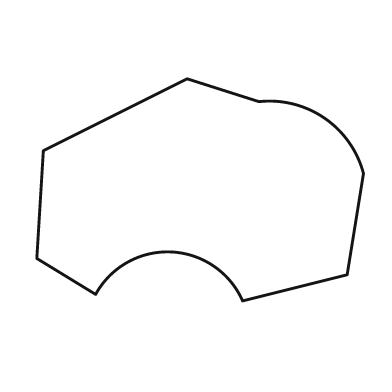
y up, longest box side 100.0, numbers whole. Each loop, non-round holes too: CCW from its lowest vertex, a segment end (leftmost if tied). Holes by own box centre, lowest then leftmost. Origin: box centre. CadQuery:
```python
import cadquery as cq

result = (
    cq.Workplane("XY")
    .moveTo(13.0, -34.0)
    .lineTo(45.0, -26.0)
    .lineTo(50.0, 5.0)
    .threePointArc((38.0, 22.0), (18.0, 27.0))
    .lineTo(-4.0, 34.0)
    .lineTo(-48.0, 12.0)
    .lineTo(-50.0, -21.0)
    .lineTo(-32.0, -32.0)
    .threePointArc((-9.0, -19.0), (13.0, -34.0))
    .close()
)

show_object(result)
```